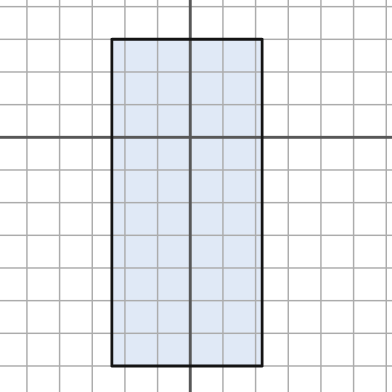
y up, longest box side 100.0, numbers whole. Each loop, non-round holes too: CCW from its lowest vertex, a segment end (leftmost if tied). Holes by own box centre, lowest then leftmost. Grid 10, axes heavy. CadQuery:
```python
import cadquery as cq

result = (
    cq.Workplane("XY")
    .moveTo(-24.0, -70.0)
    .lineTo(22.0, -70.0)
    .lineTo(22.0, 30.0)
    .lineTo(-24.0, 30.0)
    .close()
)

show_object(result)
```